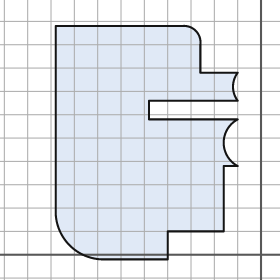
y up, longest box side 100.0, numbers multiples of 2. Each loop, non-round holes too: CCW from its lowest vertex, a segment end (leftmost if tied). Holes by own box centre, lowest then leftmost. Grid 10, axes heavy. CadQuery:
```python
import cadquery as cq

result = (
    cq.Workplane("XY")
    .moveTo(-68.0, -2.0)
    .lineTo(-40.0, -2.0)
    .lineTo(-40.0, 10.0)
    .lineTo(-16.0, 10.0)
    .lineTo(-16.0, 38.0)
    .lineTo(-10.0, 38.0)
    .threePointArc((-16.0, 48.0), (-10.0, 58.0))
    .lineTo(-48.0, 58.0)
    .lineTo(-48.0, 66.0)
    .lineTo(-10.0, 66.0)
    .threePointArc((-12.0, 72.0), (-10.0, 78.0))
    .lineTo(-26.0, 78.0)
    .lineTo(-26.0, 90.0)
    .threePointArc((-28.0, 96.0), (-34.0, 98.0))
    .lineTo(-88.0, 98.0)
    .lineTo(-88.0, 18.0)
    .threePointArc((-82.0, 4.0), (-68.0, -2.0))
    .close()
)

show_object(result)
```